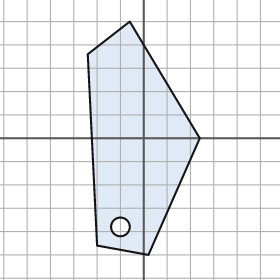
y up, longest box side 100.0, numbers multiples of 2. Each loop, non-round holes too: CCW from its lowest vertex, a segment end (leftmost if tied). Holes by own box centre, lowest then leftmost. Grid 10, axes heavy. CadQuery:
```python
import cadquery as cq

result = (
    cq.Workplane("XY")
    .moveTo(2.0, -50.0)
    .lineTo(24.0, 0.0)
    .lineTo(-6.0, 50.0)
    .lineTo(-24.0, 36.0)
    .lineTo(-20.0, -46.0)
    .close()
    .moveTo(-10.0, -38.0)
    .circle(4.0)
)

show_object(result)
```